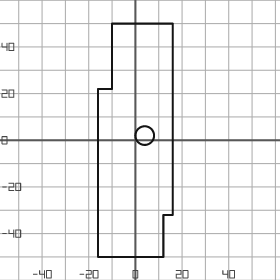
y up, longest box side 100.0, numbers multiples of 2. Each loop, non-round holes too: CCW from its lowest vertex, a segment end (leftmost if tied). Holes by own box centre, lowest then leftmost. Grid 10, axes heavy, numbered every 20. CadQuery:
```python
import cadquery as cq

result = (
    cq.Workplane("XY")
    .moveTo(-16.0, -50.0)
    .lineTo(12.0, -50.0)
    .lineTo(12.0, -32.0)
    .lineTo(16.0, -32.0)
    .lineTo(16.0, 50.0)
    .lineTo(-10.0, 50.0)
    .lineTo(-10.0, 22.0)
    .lineTo(-16.0, 22.0)
    .close()
    .moveTo(4.0, 2.0)
    .circle(4.0)
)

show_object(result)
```